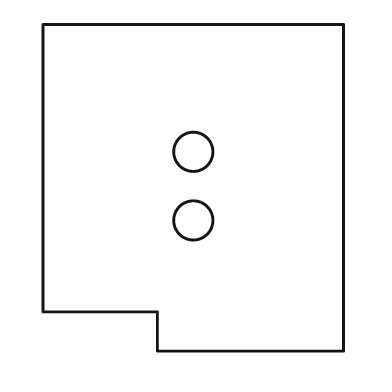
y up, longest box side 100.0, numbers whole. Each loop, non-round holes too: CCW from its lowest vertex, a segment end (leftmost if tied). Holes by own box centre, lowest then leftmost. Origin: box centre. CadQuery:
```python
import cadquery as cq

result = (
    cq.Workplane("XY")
    .moveTo(-11.0, -50.0)
    .lineTo(46.0, -50.0)
    .lineTo(46.0, 50.0)
    .lineTo(-46.0, 50.0)
    .lineTo(-46.0, -38.0)
    .lineTo(-11.0, -38.0)
    .close()
    .moveTo(0.0, -10.0)
    .circle(6.0)
    .moveTo(0.0, 11.0)
    .circle(6.0)
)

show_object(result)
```